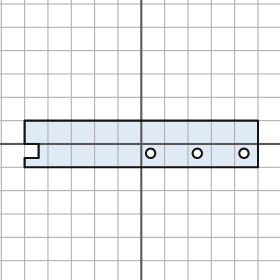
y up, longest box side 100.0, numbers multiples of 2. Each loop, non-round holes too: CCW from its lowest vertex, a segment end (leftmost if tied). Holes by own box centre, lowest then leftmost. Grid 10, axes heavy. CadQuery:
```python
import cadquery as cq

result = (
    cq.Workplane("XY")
    .moveTo(-50.0, -10.0)
    .lineTo(50.0, -10.0)
    .lineTo(50.0, 10.0)
    .lineTo(-50.0, 10.0)
    .lineTo(-50.0, 0.0)
    .lineTo(-44.0, 0.0)
    .lineTo(-44.0, -6.0)
    .lineTo(-50.0, -6.0)
    .close()
    .moveTo(4.0, -4.0)
    .circle(2.0)
    .moveTo(24.0, -4.0)
    .circle(2.0)
    .moveTo(44.0, -4.0)
    .circle(2.0)
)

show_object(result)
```